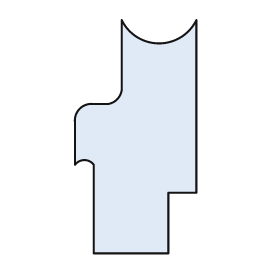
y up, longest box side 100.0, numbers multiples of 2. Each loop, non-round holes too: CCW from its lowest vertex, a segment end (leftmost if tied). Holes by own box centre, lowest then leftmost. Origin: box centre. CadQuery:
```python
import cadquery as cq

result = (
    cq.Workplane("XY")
    .moveTo(-18.0, -50.0)
    .lineTo(14.0, -50.0)
    .lineTo(14.0, -24.0)
    .lineTo(26.0, -24.0)
    .lineTo(26.0, 50.0)
    .threePointArc((10.0, 40.0), (-6.0, 50.0))
    .lineTo(-6.0, 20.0)
    .threePointArc((-8.0, 16.0), (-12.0, 14.0))
    .lineTo(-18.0, 14.0)
    .threePointArc((-24.0, 12.0), (-26.0, 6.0))
    .lineTo(-26.0, -12.0)
    .threePointArc((-22.0, -10.0), (-18.0, -12.0))
    .close()
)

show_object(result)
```